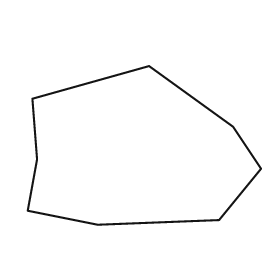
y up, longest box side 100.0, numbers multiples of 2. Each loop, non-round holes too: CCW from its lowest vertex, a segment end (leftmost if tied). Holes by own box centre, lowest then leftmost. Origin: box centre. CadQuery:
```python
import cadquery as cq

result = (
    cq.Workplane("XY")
    .moveTo(-20.0, -34.0)
    .lineTo(32.0, -32.0)
    .lineTo(50.0, -10.0)
    .lineTo(38.0, 8.0)
    .lineTo(2.0, 34.0)
    .lineTo(-48.0, 20.0)
    .lineTo(-46.0, -6.0)
    .lineTo(-50.0, -28.0)
    .close()
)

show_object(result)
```